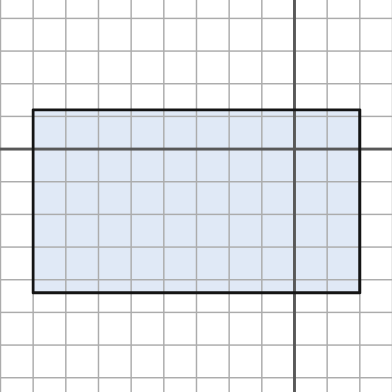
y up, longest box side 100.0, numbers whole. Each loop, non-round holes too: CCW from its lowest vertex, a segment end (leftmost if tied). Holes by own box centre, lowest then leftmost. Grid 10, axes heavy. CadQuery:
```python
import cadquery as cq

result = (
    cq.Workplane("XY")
    .moveTo(-80.0, -44.0)
    .lineTo(20.0, -44.0)
    .lineTo(20.0, 12.0)
    .lineTo(-80.0, 12.0)
    .close()
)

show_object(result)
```